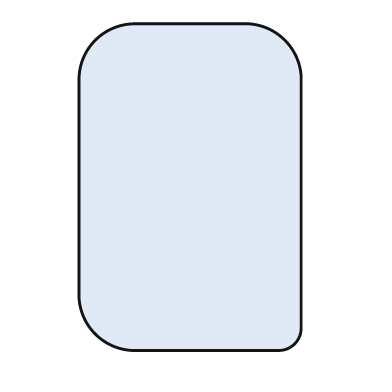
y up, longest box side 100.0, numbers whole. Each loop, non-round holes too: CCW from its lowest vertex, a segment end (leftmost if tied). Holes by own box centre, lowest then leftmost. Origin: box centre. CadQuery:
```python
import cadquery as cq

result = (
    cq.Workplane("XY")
    .moveTo(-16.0, -50.0)
    .lineTo(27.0, -50.0)
    .threePointArc((32.0, -48.0), (34.0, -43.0))
    .lineTo(34.0, 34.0)
    .threePointArc((29.0, 45.0), (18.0, 50.0))
    .lineTo(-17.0, 50.0)
    .threePointArc((-29.0, 45.0), (-34.0, 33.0))
    .lineTo(-34.0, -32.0)
    .threePointArc((-29.0, -45.0), (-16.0, -50.0))
    .close()
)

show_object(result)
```